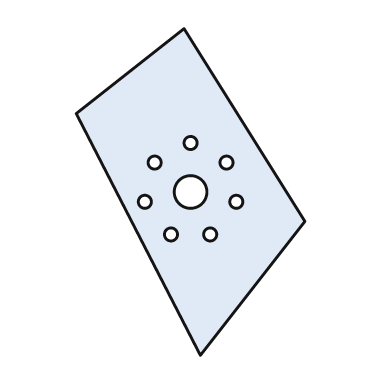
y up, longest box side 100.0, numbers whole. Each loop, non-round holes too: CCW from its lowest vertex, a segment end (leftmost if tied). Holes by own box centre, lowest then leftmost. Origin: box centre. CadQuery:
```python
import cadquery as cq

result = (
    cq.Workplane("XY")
    .moveTo(3.0, -50.0)
    .lineTo(35.0, -9.0)
    .lineTo(-2.0, 50.0)
    .lineTo(-35.0, 24.0)
    .close()
    .moveTo(-6.0, -13.0)
    .circle(2.0)
    .moveTo(6.0, -13.0)
    .circle(2.0)
    .moveTo(-14.0, -3.0)
    .circle(2.0)
    .moveTo(14.0, -3.0)
    .circle(2.0)
    .moveTo(0.0, 0.0)
    .circle(5.0)
    .moveTo(-11.0, 9.0)
    .circle(2.0)
    .moveTo(11.0, 9.0)
    .circle(2.0)
    .moveTo(0.0, 15.0)
    .circle(2.0)
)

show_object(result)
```